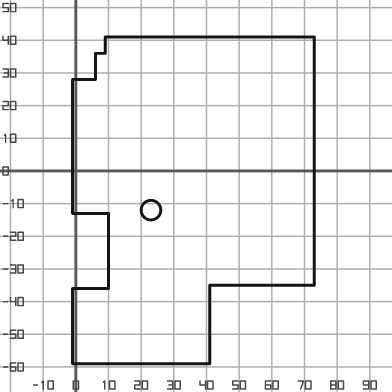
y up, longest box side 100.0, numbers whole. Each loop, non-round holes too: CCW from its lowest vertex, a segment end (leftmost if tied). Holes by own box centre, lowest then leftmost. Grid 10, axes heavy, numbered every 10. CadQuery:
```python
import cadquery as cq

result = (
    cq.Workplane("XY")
    .moveTo(-1.0, -59.0)
    .lineTo(41.0, -59.0)
    .lineTo(41.0, -35.0)
    .lineTo(73.0, -35.0)
    .lineTo(73.0, 41.0)
    .lineTo(9.0, 41.0)
    .lineTo(9.0, 36.0)
    .lineTo(6.0, 36.0)
    .lineTo(6.0, 28.0)
    .lineTo(-1.0, 28.0)
    .lineTo(-1.0, -13.0)
    .lineTo(10.0, -13.0)
    .lineTo(10.0, -36.0)
    .lineTo(-1.0, -36.0)
    .close()
    .moveTo(23.0, -12.0)
    .circle(3.0)
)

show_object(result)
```